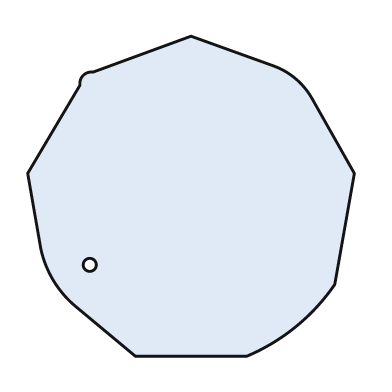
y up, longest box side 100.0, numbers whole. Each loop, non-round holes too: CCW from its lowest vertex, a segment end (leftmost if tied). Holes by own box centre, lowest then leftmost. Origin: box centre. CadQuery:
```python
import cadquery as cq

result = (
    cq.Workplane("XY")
    .moveTo(-17.0, -49.0)
    .lineTo(17.0, -49.0)
    .threePointArc((32.0, -40.0), (44.0, -27.0))
    .lineTo(50.0, 7.0)
    .lineTo(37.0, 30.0)
    .threePointArc((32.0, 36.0), (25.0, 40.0))
    .lineTo(0.0, 49.0)
    .lineTo(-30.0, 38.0)
    .threePointArc((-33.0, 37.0), (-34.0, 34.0))
    .lineTo(-50.0, 7.0)
    .lineTo(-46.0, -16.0)
    .threePointArc((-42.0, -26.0), (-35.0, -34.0))
    .close()
    .moveTo(-31.0, -21.0)
    .circle(2.0)
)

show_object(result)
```